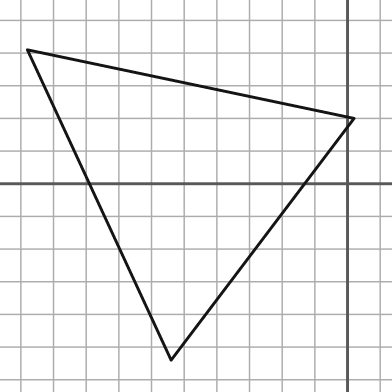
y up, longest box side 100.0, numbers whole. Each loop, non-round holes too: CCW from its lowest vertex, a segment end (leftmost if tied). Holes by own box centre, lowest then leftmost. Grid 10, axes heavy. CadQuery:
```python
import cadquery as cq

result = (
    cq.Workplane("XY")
    .moveTo(-54.0, -54.0)
    .lineTo(2.0, 20.0)
    .lineTo(-98.0, 41.0)
    .close()
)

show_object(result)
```